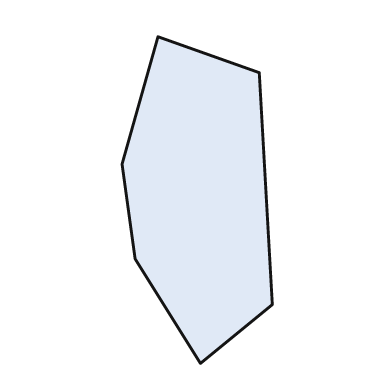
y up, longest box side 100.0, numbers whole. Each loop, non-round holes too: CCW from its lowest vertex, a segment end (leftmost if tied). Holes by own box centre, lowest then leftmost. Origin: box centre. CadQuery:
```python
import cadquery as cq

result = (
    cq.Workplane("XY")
    .moveTo(1.0, -50.0)
    .lineTo(23.0, -32.0)
    .lineTo(19.0, 39.0)
    .lineTo(-12.0, 50.0)
    .lineTo(-23.0, 11.0)
    .lineTo(-19.0, -18.0)
    .close()
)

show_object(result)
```